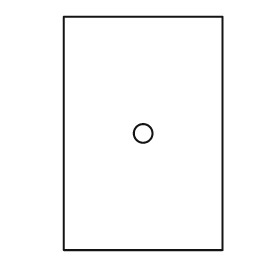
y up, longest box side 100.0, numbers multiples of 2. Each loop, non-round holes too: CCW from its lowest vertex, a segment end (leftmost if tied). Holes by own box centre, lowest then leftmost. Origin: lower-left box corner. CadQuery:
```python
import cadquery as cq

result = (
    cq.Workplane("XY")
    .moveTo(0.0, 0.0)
    .lineTo(68.0, 0.0)
    .lineTo(68.0, 100.0)
    .lineTo(0.0, 100.0)
    .close()
    .moveTo(34.0, 50.0)
    .circle(4.0)
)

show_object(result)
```